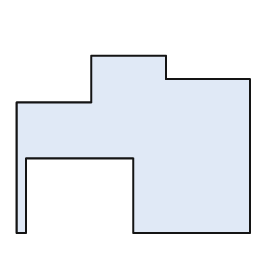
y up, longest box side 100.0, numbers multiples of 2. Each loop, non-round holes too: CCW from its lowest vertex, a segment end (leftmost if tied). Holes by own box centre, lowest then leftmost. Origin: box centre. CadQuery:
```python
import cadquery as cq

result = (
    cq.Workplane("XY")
    .moveTo(-50.0, -38.0)
    .lineTo(-46.0, -38.0)
    .lineTo(-46.0, -6.0)
    .lineTo(0.0, -6.0)
    .lineTo(0.0, -38.0)
    .lineTo(50.0, -38.0)
    .lineTo(50.0, 28.0)
    .lineTo(14.0, 28.0)
    .lineTo(14.0, 38.0)
    .lineTo(-18.0, 38.0)
    .lineTo(-18.0, 18.0)
    .lineTo(-50.0, 18.0)
    .close()
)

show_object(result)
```